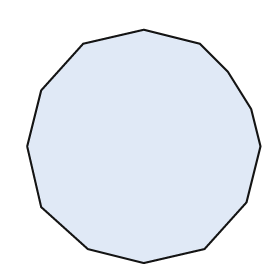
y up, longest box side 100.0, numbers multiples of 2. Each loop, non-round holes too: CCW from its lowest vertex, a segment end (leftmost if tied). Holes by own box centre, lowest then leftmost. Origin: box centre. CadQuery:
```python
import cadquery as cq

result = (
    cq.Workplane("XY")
    .moveTo(0.0, -50.0)
    .lineTo(26.0, -44.0)
    .lineTo(44.0, -24.0)
    .lineTo(50.0, 0.0)
    .lineTo(46.0, 16.0)
    .lineTo(36.0, 32.0)
    .lineTo(24.0, 44.0)
    .lineTo(0.0, 50.0)
    .lineTo(-26.0, 44.0)
    .lineTo(-44.0, 24.0)
    .lineTo(-50.0, 0.0)
    .lineTo(-44.0, -26.0)
    .lineTo(-24.0, -44.0)
    .close()
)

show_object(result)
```